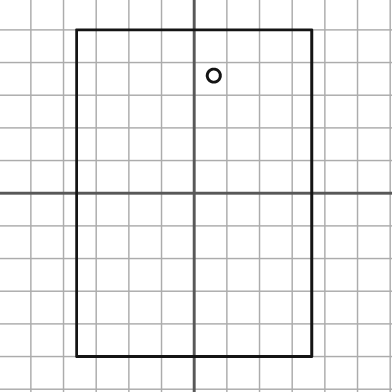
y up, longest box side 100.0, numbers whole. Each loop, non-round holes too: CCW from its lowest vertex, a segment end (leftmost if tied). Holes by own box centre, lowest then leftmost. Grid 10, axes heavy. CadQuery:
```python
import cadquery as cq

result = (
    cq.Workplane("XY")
    .moveTo(-36.0, -50.0)
    .lineTo(36.0, -50.0)
    .lineTo(36.0, 50.0)
    .lineTo(-36.0, 50.0)
    .close()
    .moveTo(6.0, 36.0)
    .circle(2.0)
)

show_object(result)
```